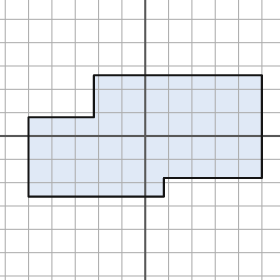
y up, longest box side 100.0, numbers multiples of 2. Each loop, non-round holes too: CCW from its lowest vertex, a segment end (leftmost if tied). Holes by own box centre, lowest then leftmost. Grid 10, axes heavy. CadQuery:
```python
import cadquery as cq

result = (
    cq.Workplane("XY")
    .moveTo(-50.0, -26.0)
    .lineTo(8.0, -26.0)
    .lineTo(8.0, -18.0)
    .lineTo(50.0, -18.0)
    .lineTo(50.0, 26.0)
    .lineTo(-22.0, 26.0)
    .lineTo(-22.0, 8.0)
    .lineTo(-50.0, 8.0)
    .close()
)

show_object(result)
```